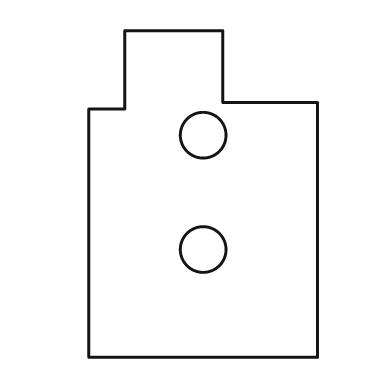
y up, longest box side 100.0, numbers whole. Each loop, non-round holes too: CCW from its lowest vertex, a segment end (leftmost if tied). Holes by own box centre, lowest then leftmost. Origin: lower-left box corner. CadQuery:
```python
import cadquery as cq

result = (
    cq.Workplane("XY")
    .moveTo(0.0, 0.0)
    .lineTo(70.0, 0.0)
    .lineTo(70.0, 78.0)
    .lineTo(41.0, 78.0)
    .lineTo(41.0, 100.0)
    .lineTo(11.0, 100.0)
    .lineTo(11.0, 76.0)
    .lineTo(0.0, 76.0)
    .close()
    .moveTo(35.0, 33.0)
    .circle(7.0)
    .moveTo(35.0, 68.0)
    .circle(7.0)
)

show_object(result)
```